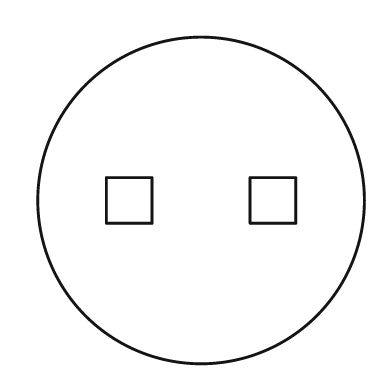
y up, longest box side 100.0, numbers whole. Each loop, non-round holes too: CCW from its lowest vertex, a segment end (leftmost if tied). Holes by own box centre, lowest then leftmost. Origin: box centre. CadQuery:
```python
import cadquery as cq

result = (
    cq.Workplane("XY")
    .moveTo(0.0, 0.0)
    .circle(50.0)
    .moveTo(-29.0, -7.0)
    .lineTo(-15.0, -7.0)
    .lineTo(-15.0, 7.0)
    .lineTo(-29.0, 7.0)
    .close()
    .moveTo(15.0, -7.0)
    .lineTo(29.0, -7.0)
    .lineTo(29.0, 7.0)
    .lineTo(15.0, 7.0)
    .close()
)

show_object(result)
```